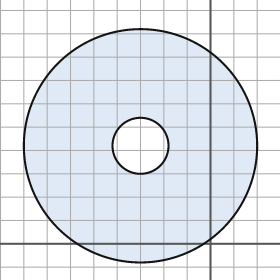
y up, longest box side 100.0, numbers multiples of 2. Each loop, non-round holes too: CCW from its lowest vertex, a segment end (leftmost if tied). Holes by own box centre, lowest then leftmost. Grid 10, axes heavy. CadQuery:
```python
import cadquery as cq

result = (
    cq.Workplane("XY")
    .moveTo(-30.0, 42.0)
    .circle(50.0)
    .moveTo(-30.0, 42.0)
    .circle(12.0)
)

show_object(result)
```